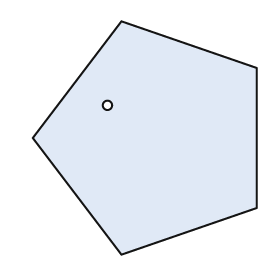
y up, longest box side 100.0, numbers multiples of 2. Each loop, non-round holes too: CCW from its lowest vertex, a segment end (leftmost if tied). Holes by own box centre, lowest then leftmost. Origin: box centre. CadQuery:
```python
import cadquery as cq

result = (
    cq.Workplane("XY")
    .moveTo(-10.0, -50.0)
    .lineTo(48.0, -30.0)
    .lineTo(48.0, 30.0)
    .lineTo(-10.0, 50.0)
    .lineTo(-48.0, 0.0)
    .close()
    .moveTo(-16.0, 14.0)
    .circle(2.0)
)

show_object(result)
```